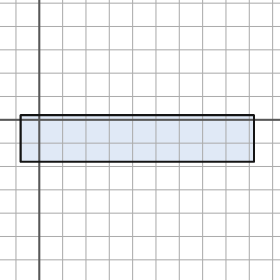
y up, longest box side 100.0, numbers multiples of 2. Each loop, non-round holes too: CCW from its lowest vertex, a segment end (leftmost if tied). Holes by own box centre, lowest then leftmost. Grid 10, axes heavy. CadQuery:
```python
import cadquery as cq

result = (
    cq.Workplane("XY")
    .moveTo(-8.0, -18.0)
    .lineTo(92.0, -18.0)
    .lineTo(92.0, 2.0)
    .lineTo(-8.0, 2.0)
    .close()
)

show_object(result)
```